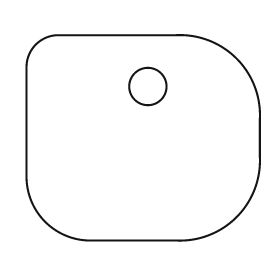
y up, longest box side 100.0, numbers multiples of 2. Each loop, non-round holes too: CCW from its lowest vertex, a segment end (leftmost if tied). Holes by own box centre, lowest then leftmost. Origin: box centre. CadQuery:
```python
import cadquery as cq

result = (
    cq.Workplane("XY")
    .moveTo(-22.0, -44.0)
    .lineTo(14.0, -44.0)
    .threePointArc((40.0, -34.0), (50.0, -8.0))
    .lineTo(50.0, 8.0)
    .threePointArc((40.0, 34.0), (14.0, 44.0))
    .lineTo(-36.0, 44.0)
    .threePointArc((-46.0, 40.0), (-50.0, 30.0))
    .lineTo(-50.0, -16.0)
    .threePointArc((-42.0, -36.0), (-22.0, -44.0))
    .close()
    .moveTo(2.0, 22.0)
    .circle(8.0)
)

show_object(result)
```